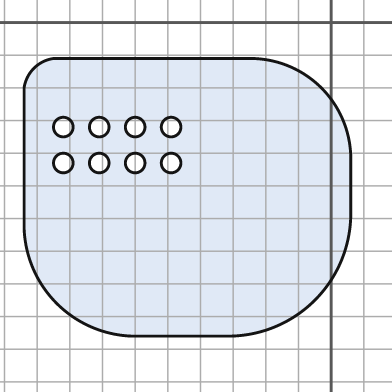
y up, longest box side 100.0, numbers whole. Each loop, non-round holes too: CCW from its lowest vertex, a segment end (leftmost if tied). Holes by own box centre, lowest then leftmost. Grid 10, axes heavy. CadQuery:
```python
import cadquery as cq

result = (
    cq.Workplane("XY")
    .moveTo(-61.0, -96.0)
    .lineTo(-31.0, -96.0)
    .threePointArc((-5.0, -85.0), (6.0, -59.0))
    .lineTo(6.0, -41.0)
    .threePointArc((-3.0, -20.0), (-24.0, -11.0))
    .lineTo(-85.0, -11.0)
    .threePointArc((-91.0, -14.0), (-94.0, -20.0))
    .lineTo(-94.0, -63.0)
    .threePointArc((-84.0, -86.0), (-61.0, -96.0))
    .close()
    .moveTo(-82.0, -43.0)
    .circle(3.0)
    .moveTo(-71.0, -43.0)
    .circle(3.0)
    .moveTo(-60.0, -43.0)
    .circle(3.0)
    .moveTo(-49.0, -43.0)
    .circle(3.0)
    .moveTo(-82.0, -32.0)
    .circle(3.0)
    .moveTo(-71.0, -32.0)
    .circle(3.0)
    .moveTo(-60.0, -32.0)
    .circle(3.0)
    .moveTo(-49.0, -32.0)
    .circle(3.0)
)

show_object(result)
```